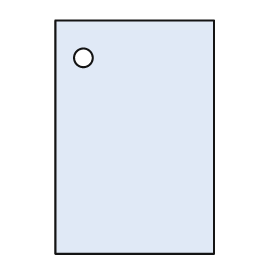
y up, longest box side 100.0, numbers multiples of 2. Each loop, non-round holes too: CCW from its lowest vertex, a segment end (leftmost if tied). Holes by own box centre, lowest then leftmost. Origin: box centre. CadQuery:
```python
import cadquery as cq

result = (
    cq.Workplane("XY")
    .moveTo(-34.0, -50.0)
    .lineTo(34.0, -50.0)
    .lineTo(34.0, 50.0)
    .lineTo(-34.0, 50.0)
    .close()
    .moveTo(-22.0, 34.0)
    .circle(4.0)
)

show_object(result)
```